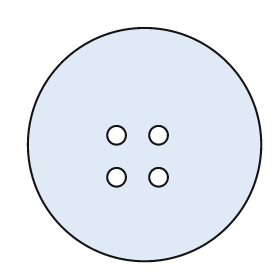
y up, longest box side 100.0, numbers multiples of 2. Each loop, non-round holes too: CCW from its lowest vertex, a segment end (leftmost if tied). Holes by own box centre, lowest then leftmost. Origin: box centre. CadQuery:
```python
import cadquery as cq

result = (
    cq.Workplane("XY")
    .moveTo(0.0, 0.0)
    .circle(50.0)
    .moveTo(-12.0, -14.0)
    .circle(4.0)
    .moveTo(6.0, -14.0)
    .circle(4.0)
    .moveTo(-12.0, 4.0)
    .circle(4.0)
    .moveTo(6.0, 4.0)
    .circle(4.0)
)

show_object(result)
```